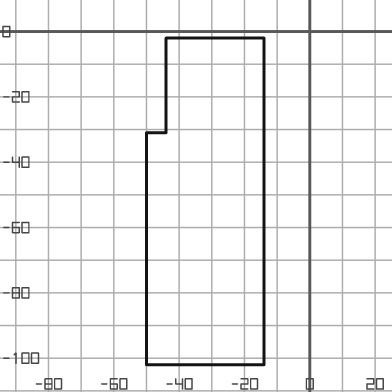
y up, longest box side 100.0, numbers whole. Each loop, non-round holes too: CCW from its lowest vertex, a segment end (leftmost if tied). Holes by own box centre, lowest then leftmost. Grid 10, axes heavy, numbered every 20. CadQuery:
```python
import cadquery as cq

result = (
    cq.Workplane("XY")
    .moveTo(-50.0, -102.0)
    .lineTo(-14.0, -102.0)
    .lineTo(-14.0, -2.0)
    .lineTo(-44.0, -2.0)
    .lineTo(-44.0, -31.0)
    .lineTo(-50.0, -31.0)
    .close()
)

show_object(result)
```